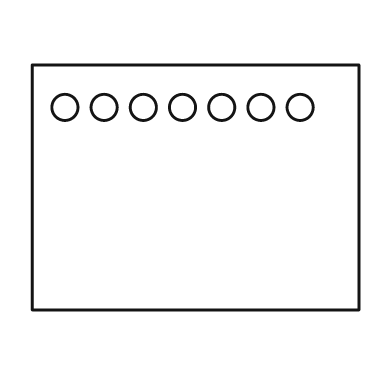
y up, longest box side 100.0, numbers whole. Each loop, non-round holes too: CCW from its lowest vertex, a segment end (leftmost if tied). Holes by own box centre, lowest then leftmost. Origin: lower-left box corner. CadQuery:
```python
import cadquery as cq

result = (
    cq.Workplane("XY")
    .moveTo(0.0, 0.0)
    .lineTo(100.0, 0.0)
    .lineTo(100.0, 75.0)
    .lineTo(0.0, 75.0)
    .close()
    .moveTo(10.0, 62.0)
    .circle(4.0)
    .moveTo(22.0, 62.0)
    .circle(4.0)
    .moveTo(34.0, 62.0)
    .circle(4.0)
    .moveTo(46.0, 62.0)
    .circle(4.0)
    .moveTo(58.0, 62.0)
    .circle(4.0)
    .moveTo(70.0, 62.0)
    .circle(4.0)
    .moveTo(82.0, 62.0)
    .circle(4.0)
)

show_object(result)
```